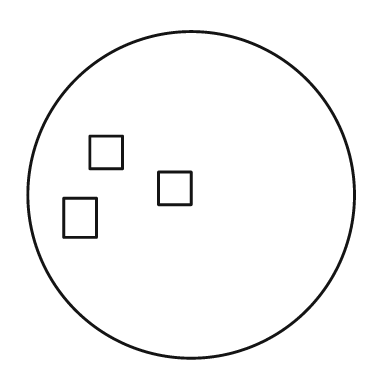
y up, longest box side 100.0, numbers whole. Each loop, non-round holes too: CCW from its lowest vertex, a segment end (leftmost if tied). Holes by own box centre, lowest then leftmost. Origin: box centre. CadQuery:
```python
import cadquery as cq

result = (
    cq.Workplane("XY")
    .moveTo(0.0, 0.0)
    .circle(50.0)
    .moveTo(-39.0, -13.0)
    .lineTo(-29.0, -13.0)
    .lineTo(-29.0, -1.0)
    .lineTo(-39.0, -1.0)
    .close()
    .moveTo(-10.0, -3.0)
    .lineTo(0.0, -3.0)
    .lineTo(0.0, 7.0)
    .lineTo(-10.0, 7.0)
    .close()
    .moveTo(-31.0, 8.0)
    .lineTo(-21.0, 8.0)
    .lineTo(-21.0, 18.0)
    .lineTo(-31.0, 18.0)
    .close()
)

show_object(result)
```